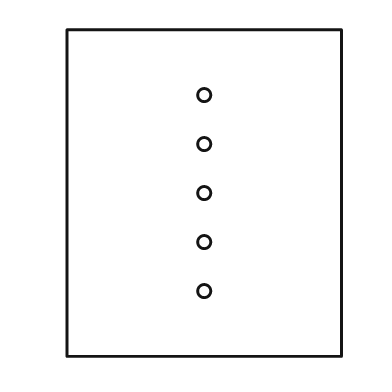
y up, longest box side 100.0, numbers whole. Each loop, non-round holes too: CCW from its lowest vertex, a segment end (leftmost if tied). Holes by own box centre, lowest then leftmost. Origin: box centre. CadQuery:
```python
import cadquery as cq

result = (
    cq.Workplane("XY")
    .moveTo(-42.0, -50.0)
    .lineTo(42.0, -50.0)
    .lineTo(42.0, 50.0)
    .lineTo(-42.0, 50.0)
    .close()
    .moveTo(0.0, -30.0)
    .circle(2.0)
    .moveTo(0.0, -15.0)
    .circle(2.0)
    .moveTo(0.0, 0.0)
    .circle(2.0)
    .moveTo(0.0, 15.0)
    .circle(2.0)
    .moveTo(0.0, 30.0)
    .circle(2.0)
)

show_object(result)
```